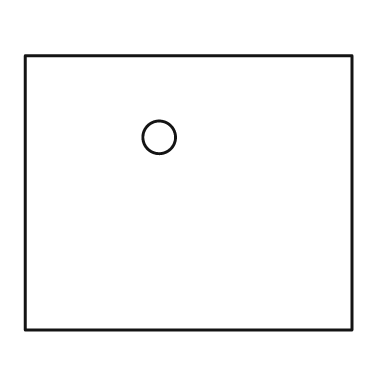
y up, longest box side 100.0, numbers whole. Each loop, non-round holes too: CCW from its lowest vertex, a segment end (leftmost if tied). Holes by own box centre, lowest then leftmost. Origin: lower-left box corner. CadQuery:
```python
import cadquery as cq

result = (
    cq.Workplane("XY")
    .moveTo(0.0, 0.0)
    .lineTo(100.0, 0.0)
    .lineTo(100.0, 84.0)
    .lineTo(0.0, 84.0)
    .close()
    .moveTo(41.0, 59.0)
    .circle(5.0)
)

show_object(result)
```